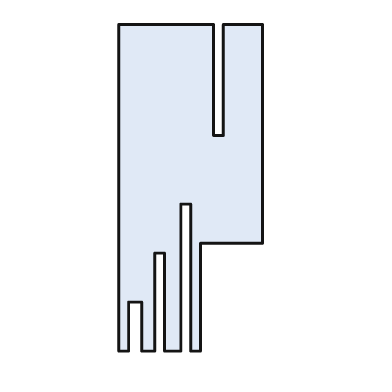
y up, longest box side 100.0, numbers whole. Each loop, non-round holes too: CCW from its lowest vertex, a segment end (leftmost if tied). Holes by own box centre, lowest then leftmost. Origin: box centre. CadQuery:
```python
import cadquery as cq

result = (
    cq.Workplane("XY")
    .moveTo(-22.0, -50.0)
    .lineTo(-19.0, -50.0)
    .lineTo(-19.0, -35.0)
    .lineTo(-15.0, -35.0)
    .lineTo(-15.0, -50.0)
    .lineTo(-11.0, -50.0)
    .lineTo(-11.0, -20.0)
    .lineTo(-8.0, -20.0)
    .lineTo(-8.0, -50.0)
    .lineTo(-3.0, -50.0)
    .lineTo(-3.0, -5.0)
    .lineTo(0.0, -5.0)
    .lineTo(0.0, -50.0)
    .lineTo(3.0, -50.0)
    .lineTo(3.0, -17.0)
    .lineTo(22.0, -17.0)
    .lineTo(22.0, 50.0)
    .lineTo(10.0, 50.0)
    .lineTo(10.0, 16.0)
    .lineTo(7.0, 16.0)
    .lineTo(7.0, 50.0)
    .lineTo(-22.0, 50.0)
    .close()
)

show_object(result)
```